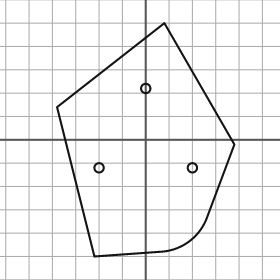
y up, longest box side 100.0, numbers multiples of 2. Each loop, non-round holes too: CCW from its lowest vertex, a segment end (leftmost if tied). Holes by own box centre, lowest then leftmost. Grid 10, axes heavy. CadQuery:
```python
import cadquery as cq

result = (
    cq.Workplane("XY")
    .moveTo(-22.0, -50.0)
    .lineTo(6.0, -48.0)
    .threePointArc((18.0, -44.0), (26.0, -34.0))
    .lineTo(38.0, -2.0)
    .lineTo(8.0, 50.0)
    .lineTo(-38.0, 14.0)
    .close()
    .moveTo(-20.0, -12.0)
    .circle(2.0)
    .moveTo(20.0, -12.0)
    .circle(2.0)
    .moveTo(0.0, 22.0)
    .circle(2.0)
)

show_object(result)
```